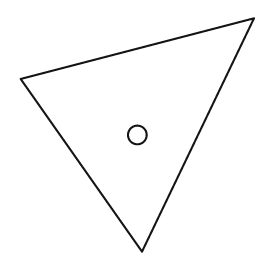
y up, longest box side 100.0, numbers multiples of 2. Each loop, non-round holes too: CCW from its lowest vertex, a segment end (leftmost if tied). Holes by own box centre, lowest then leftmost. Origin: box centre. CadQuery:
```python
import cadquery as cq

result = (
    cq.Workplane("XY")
    .moveTo(2.0, -50.0)
    .lineTo(50.0, 50.0)
    .lineTo(-50.0, 24.0)
    .close()
    .moveTo(0.0, 0.0)
    .circle(4.0)
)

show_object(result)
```